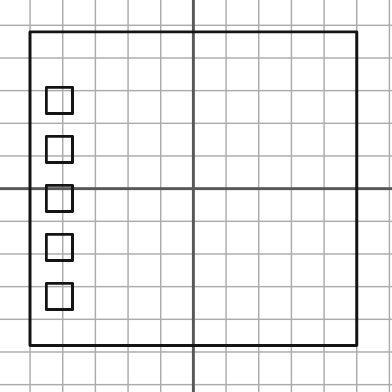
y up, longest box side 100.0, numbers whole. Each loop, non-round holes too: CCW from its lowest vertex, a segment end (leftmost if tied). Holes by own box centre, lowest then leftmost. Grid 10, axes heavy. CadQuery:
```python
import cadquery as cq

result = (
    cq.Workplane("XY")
    .moveTo(-50.0, -48.0)
    .lineTo(50.0, -48.0)
    .lineTo(50.0, 48.0)
    .lineTo(-50.0, 48.0)
    .close()
    .moveTo(-45.0, -37.0)
    .lineTo(-37.0, -37.0)
    .lineTo(-37.0, -29.0)
    .lineTo(-45.0, -29.0)
    .close()
    .moveTo(-45.0, -22.0)
    .lineTo(-37.0, -22.0)
    .lineTo(-37.0, -14.0)
    .lineTo(-45.0, -14.0)
    .close()
    .moveTo(-45.0, -7.0)
    .lineTo(-37.0, -7.0)
    .lineTo(-37.0, 1.0)
    .lineTo(-45.0, 1.0)
    .close()
    .moveTo(-45.0, 8.0)
    .lineTo(-37.0, 8.0)
    .lineTo(-37.0, 16.0)
    .lineTo(-45.0, 16.0)
    .close()
    .moveTo(-45.0, 23.0)
    .lineTo(-37.0, 23.0)
    .lineTo(-37.0, 31.0)
    .lineTo(-45.0, 31.0)
    .close()
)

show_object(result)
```